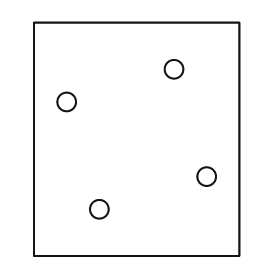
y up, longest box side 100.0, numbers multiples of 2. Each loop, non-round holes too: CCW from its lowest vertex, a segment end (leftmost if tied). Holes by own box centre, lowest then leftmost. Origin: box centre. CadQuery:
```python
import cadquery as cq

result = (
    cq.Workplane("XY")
    .moveTo(-44.0, -50.0)
    .lineTo(44.0, -50.0)
    .lineTo(44.0, 50.0)
    .lineTo(-44.0, 50.0)
    .close()
    .moveTo(-16.0, -30.0)
    .circle(4.0)
    .moveTo(30.0, -16.0)
    .circle(4.0)
    .moveTo(-30.0, 16.0)
    .circle(4.0)
    .moveTo(16.0, 30.0)
    .circle(4.0)
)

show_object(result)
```